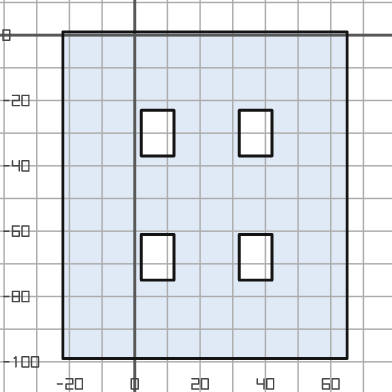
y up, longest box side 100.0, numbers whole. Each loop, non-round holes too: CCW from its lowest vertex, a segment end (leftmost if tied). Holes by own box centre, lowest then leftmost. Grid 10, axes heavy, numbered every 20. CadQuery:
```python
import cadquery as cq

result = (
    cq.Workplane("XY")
    .moveTo(-22.0, -99.0)
    .lineTo(65.0, -99.0)
    .lineTo(65.0, 1.0)
    .lineTo(-22.0, 1.0)
    .close()
    .moveTo(2.0, -75.0)
    .lineTo(12.0, -75.0)
    .lineTo(12.0, -61.0)
    .lineTo(2.0, -61.0)
    .close()
    .moveTo(32.0, -75.0)
    .lineTo(42.0, -75.0)
    .lineTo(42.0, -61.0)
    .lineTo(32.0, -61.0)
    .close()
    .moveTo(2.0, -37.0)
    .lineTo(12.0, -37.0)
    .lineTo(12.0, -23.0)
    .lineTo(2.0, -23.0)
    .close()
    .moveTo(32.0, -37.0)
    .lineTo(42.0, -37.0)
    .lineTo(42.0, -23.0)
    .lineTo(32.0, -23.0)
    .close()
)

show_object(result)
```